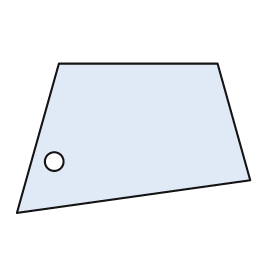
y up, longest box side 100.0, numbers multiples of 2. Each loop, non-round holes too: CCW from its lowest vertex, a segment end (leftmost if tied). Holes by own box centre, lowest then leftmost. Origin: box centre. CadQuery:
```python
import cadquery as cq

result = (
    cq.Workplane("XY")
    .moveTo(-50.0, -32.0)
    .lineTo(50.0, -18.0)
    .lineTo(36.0, 32.0)
    .lineTo(-32.0, 32.0)
    .close()
    .moveTo(-34.0, -10.0)
    .circle(4.0)
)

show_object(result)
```